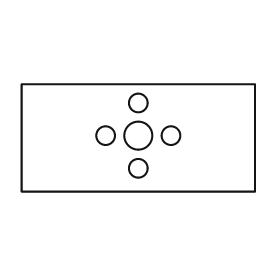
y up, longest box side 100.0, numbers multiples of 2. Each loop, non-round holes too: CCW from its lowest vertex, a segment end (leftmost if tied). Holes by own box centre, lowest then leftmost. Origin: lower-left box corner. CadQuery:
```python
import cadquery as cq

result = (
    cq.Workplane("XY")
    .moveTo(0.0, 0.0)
    .lineTo(100.0, 0.0)
    .lineTo(100.0, 46.0)
    .lineTo(0.0, 46.0)
    .close()
    .moveTo(50.0, 10.0)
    .circle(4.0)
    .moveTo(36.0, 24.0)
    .circle(4.0)
    .moveTo(50.0, 24.0)
    .circle(6.0)
    .moveTo(64.0, 24.0)
    .circle(4.0)
    .moveTo(50.0, 38.0)
    .circle(4.0)
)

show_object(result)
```